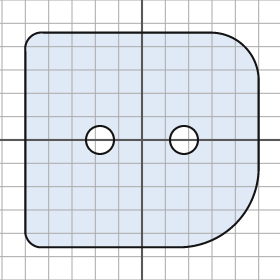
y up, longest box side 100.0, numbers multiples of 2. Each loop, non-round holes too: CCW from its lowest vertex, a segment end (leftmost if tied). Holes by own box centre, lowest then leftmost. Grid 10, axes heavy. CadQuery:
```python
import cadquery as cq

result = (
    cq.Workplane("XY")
    .moveTo(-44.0, -46.0)
    .lineTo(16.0, -46.0)
    .threePointArc((40.0, -36.0), (50.0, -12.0))
    .lineTo(50.0, 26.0)
    .threePointArc((44.0, 40.0), (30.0, 46.0))
    .lineTo(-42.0, 46.0)
    .threePointArc((-48.0, 44.0), (-50.0, 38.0))
    .lineTo(-50.0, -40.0)
    .threePointArc((-48.0, -44.0), (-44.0, -46.0))
    .close()
    .moveTo(-18.0, 0.0)
    .circle(6.0)
    .moveTo(18.0, 0.0)
    .circle(6.0)
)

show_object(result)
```